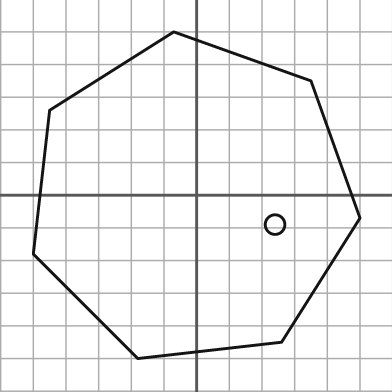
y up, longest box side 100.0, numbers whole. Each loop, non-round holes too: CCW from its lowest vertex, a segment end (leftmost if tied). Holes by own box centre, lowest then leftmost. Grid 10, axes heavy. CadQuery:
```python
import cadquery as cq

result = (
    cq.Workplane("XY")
    .moveTo(-18.0, -50.0)
    .lineTo(26.0, -45.0)
    .lineTo(50.0, -7.0)
    .lineTo(35.0, 35.0)
    .lineTo(-7.0, 50.0)
    .lineTo(-45.0, 26.0)
    .lineTo(-50.0, -18.0)
    .close()
    .moveTo(24.0, -9.0)
    .circle(3.0)
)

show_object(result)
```